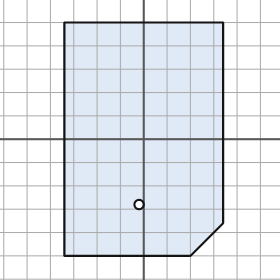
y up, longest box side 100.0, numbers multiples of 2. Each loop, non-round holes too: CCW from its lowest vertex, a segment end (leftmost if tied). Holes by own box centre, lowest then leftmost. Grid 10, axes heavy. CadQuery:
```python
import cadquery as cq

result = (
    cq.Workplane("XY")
    .moveTo(-34.0, -50.0)
    .lineTo(20.0, -50.0)
    .lineTo(34.0, -36.0)
    .lineTo(34.0, 50.0)
    .lineTo(-34.0, 50.0)
    .close()
    .moveTo(-2.0, -28.0)
    .circle(2.0)
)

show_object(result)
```